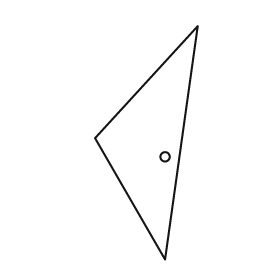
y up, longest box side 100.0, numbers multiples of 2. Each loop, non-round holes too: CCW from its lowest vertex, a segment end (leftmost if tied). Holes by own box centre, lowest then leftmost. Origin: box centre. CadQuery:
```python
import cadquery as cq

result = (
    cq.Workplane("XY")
    .moveTo(8.0, -50.0)
    .lineTo(22.0, 50.0)
    .lineTo(-22.0, 2.0)
    .close()
    .moveTo(8.0, -6.0)
    .circle(2.0)
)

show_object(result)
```